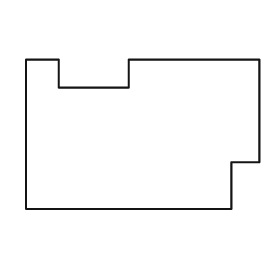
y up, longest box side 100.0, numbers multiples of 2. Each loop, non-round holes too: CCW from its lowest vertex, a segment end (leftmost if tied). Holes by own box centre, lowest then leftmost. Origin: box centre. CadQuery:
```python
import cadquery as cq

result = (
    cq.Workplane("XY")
    .moveTo(-50.0, -32.0)
    .lineTo(38.0, -32.0)
    .lineTo(38.0, -12.0)
    .lineTo(50.0, -12.0)
    .lineTo(50.0, 32.0)
    .lineTo(-6.0, 32.0)
    .lineTo(-6.0, 20.0)
    .lineTo(-36.0, 20.0)
    .lineTo(-36.0, 32.0)
    .lineTo(-50.0, 32.0)
    .close()
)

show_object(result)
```